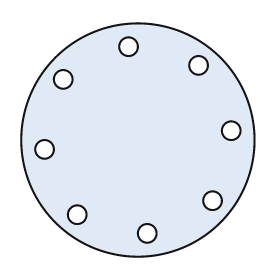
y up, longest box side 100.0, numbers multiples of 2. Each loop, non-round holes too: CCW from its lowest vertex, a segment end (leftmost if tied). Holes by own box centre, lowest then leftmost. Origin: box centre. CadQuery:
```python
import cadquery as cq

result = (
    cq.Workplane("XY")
    .moveTo(0.0, 0.0)
    .circle(50.0)
    .moveTo(4.0, -40.0)
    .circle(4.0)
    .moveTo(-26.0, -32.0)
    .circle(4.0)
    .moveTo(32.0, -26.0)
    .circle(4.0)
    .moveTo(-40.0, -4.0)
    .circle(4.0)
    .moveTo(40.0, 4.0)
    .circle(4.0)
    .moveTo(-32.0, 26.0)
    .circle(4.0)
    .moveTo(26.0, 32.0)
    .circle(4.0)
    .moveTo(-4.0, 40.0)
    .circle(4.0)
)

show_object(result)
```